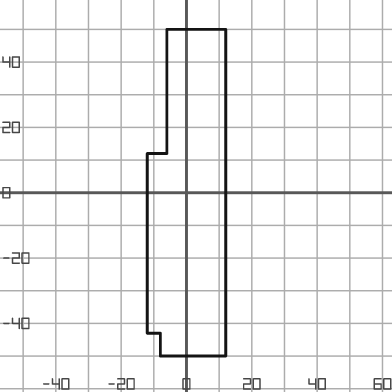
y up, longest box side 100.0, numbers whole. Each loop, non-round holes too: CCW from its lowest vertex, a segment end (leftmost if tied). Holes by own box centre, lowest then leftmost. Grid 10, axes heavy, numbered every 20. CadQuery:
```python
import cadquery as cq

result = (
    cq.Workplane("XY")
    .moveTo(-8.0, -50.0)
    .lineTo(12.0, -50.0)
    .lineTo(12.0, 50.0)
    .lineTo(-6.0, 50.0)
    .lineTo(-6.0, 12.0)
    .lineTo(-12.0, 12.0)
    .lineTo(-12.0, -43.0)
    .lineTo(-8.0, -43.0)
    .close()
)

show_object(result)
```